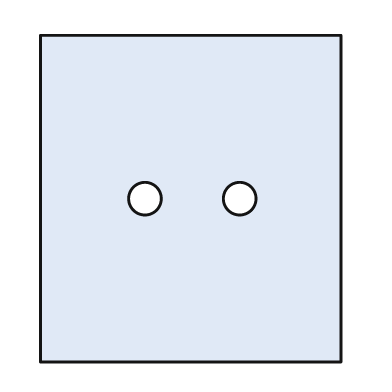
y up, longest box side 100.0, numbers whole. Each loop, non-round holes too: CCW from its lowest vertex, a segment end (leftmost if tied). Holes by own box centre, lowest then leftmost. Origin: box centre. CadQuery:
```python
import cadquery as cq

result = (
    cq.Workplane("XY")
    .moveTo(-46.0, -50.0)
    .lineTo(46.0, -50.0)
    .lineTo(46.0, 50.0)
    .lineTo(-46.0, 50.0)
    .close()
    .moveTo(-14.0, 0.0)
    .circle(5.0)
    .moveTo(15.0, 0.0)
    .circle(5.0)
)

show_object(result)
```